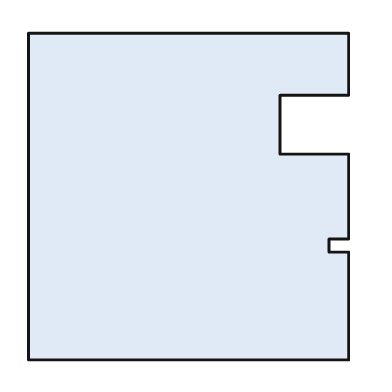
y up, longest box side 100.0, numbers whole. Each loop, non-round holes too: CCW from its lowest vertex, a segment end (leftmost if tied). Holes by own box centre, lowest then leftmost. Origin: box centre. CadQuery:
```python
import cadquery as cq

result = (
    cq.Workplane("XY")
    .moveTo(-49.0, -50.0)
    .lineTo(49.0, -50.0)
    .lineTo(49.0, -17.0)
    .lineTo(43.0, -17.0)
    .lineTo(43.0, -13.0)
    .lineTo(49.0, -13.0)
    .lineTo(49.0, 13.0)
    .lineTo(28.0, 13.0)
    .lineTo(28.0, 31.0)
    .lineTo(49.0, 31.0)
    .lineTo(49.0, 50.0)
    .lineTo(-49.0, 50.0)
    .close()
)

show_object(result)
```